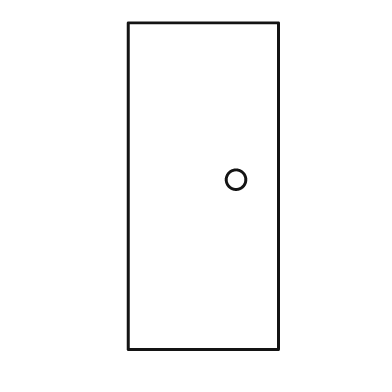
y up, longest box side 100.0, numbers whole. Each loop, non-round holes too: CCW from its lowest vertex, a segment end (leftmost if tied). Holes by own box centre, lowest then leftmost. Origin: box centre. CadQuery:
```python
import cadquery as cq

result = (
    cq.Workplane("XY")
    .moveTo(-23.0, -50.0)
    .lineTo(23.0, -50.0)
    .lineTo(23.0, 50.0)
    .lineTo(-23.0, 50.0)
    .close()
    .moveTo(10.0, 2.0)
    .circle(3.0)
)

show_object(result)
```